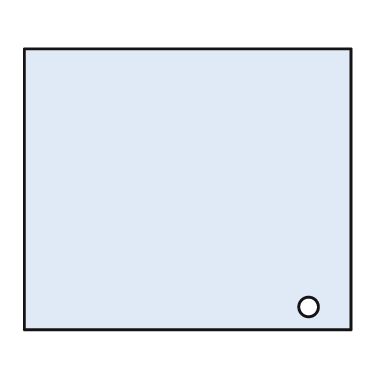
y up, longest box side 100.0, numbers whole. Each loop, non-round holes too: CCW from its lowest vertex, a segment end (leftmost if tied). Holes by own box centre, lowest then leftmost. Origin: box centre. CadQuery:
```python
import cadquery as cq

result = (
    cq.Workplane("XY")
    .moveTo(-50.0, -43.0)
    .lineTo(50.0, -43.0)
    .lineTo(50.0, 43.0)
    .lineTo(-50.0, 43.0)
    .close()
    .moveTo(37.0, -36.0)
    .circle(3.0)
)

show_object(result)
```